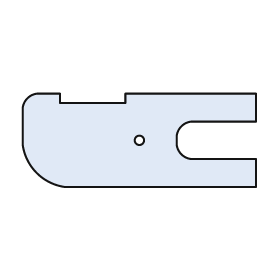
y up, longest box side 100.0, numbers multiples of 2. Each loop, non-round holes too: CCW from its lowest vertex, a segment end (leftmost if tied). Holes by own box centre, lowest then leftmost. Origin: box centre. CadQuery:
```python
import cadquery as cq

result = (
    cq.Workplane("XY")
    .moveTo(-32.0, -20.0)
    .lineTo(50.0, -20.0)
    .lineTo(50.0, -8.0)
    .lineTo(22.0, -8.0)
    .threePointArc((18.0, -6.0), (16.0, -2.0))
    .lineTo(16.0, 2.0)
    .threePointArc((18.0, 6.0), (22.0, 8.0))
    .lineTo(50.0, 8.0)
    .lineTo(50.0, 20.0)
    .lineTo(-6.0, 20.0)
    .lineTo(-6.0, 16.0)
    .lineTo(-34.0, 16.0)
    .lineTo(-34.0, 20.0)
    .lineTo(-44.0, 20.0)
    .threePointArc((-48.0, 18.0), (-50.0, 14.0))
    .lineTo(-50.0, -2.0)
    .threePointArc((-44.0, -14.0), (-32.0, -20.0))
    .close()
    .moveTo(0.0, 0.0)
    .circle(2.0)
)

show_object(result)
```